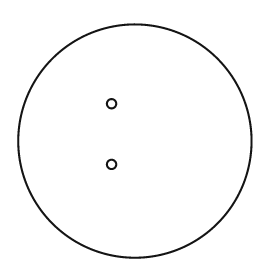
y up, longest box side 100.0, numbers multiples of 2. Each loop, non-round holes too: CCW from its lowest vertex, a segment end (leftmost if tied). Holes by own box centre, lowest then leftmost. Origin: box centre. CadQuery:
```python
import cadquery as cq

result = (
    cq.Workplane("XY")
    .moveTo(0.0, 0.0)
    .circle(50.0)
    .moveTo(-10.0, -10.0)
    .circle(2.0)
    .moveTo(-10.0, 16.0)
    .circle(2.0)
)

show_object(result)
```